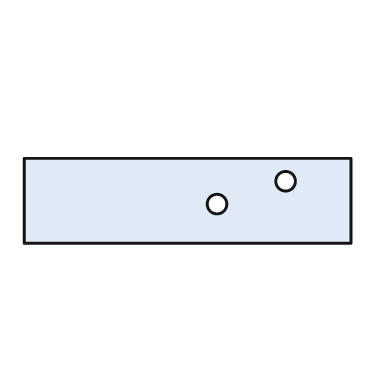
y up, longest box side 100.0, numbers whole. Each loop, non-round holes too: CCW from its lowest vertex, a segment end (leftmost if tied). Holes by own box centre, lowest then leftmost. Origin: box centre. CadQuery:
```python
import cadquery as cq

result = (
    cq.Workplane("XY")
    .moveTo(-50.0, -13.0)
    .lineTo(50.0, -13.0)
    .lineTo(50.0, 13.0)
    .lineTo(-50.0, 13.0)
    .close()
    .moveTo(9.0, -1.0)
    .circle(3.0)
    .moveTo(30.0, 6.0)
    .circle(3.0)
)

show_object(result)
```